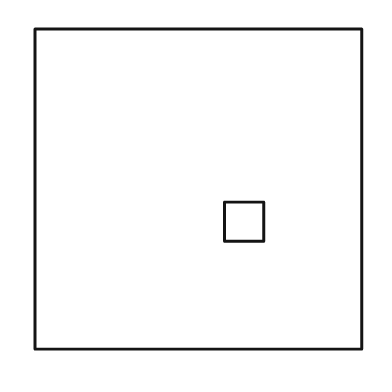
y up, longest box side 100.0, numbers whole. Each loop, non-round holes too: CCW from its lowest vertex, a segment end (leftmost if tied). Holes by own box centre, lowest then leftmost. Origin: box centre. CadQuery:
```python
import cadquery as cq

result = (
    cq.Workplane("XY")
    .moveTo(-50.0, -49.0)
    .lineTo(50.0, -49.0)
    .lineTo(50.0, 49.0)
    .lineTo(-50.0, 49.0)
    .close()
    .moveTo(8.0, -16.0)
    .lineTo(20.0, -16.0)
    .lineTo(20.0, -4.0)
    .lineTo(8.0, -4.0)
    .close()
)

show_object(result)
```